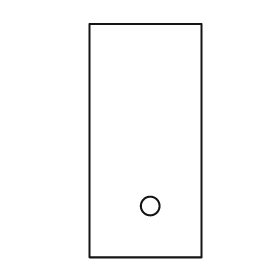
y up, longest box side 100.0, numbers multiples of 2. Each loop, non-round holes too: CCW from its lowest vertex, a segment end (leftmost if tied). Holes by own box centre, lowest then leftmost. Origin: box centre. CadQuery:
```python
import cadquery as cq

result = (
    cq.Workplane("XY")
    .moveTo(-24.0, -50.0)
    .lineTo(24.0, -50.0)
    .lineTo(24.0, 50.0)
    .lineTo(-24.0, 50.0)
    .close()
    .moveTo(2.0, -28.0)
    .circle(4.0)
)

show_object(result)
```